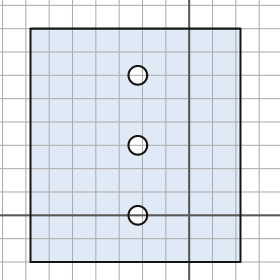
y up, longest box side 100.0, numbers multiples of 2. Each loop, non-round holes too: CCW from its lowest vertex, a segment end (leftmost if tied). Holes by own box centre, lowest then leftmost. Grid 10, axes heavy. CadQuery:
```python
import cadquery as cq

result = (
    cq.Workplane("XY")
    .moveTo(-68.0, -20.0)
    .lineTo(22.0, -20.0)
    .lineTo(22.0, 80.0)
    .lineTo(-68.0, 80.0)
    .close()
    .moveTo(-22.0, 0.0)
    .circle(4.0)
    .moveTo(-22.0, 30.0)
    .circle(4.0)
    .moveTo(-22.0, 60.0)
    .circle(4.0)
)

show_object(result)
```